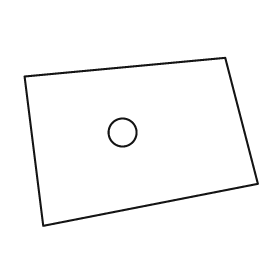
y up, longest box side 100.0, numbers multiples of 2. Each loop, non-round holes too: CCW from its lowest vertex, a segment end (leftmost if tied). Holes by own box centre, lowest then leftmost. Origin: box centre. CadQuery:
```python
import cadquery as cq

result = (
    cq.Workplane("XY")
    .moveTo(-42.0, -36.0)
    .lineTo(50.0, -18.0)
    .lineTo(36.0, 36.0)
    .lineTo(-50.0, 28.0)
    .close()
    .moveTo(-8.0, 4.0)
    .circle(6.0)
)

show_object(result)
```